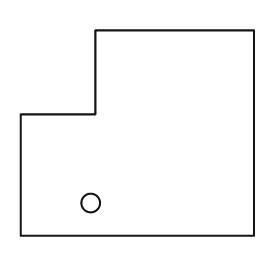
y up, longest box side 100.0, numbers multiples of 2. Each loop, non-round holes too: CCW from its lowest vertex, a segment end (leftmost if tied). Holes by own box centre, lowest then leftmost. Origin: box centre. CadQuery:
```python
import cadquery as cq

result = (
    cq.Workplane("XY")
    .moveTo(-50.0, -44.0)
    .lineTo(50.0, -44.0)
    .lineTo(50.0, 44.0)
    .lineTo(-18.0, 44.0)
    .lineTo(-18.0, 8.0)
    .lineTo(-50.0, 8.0)
    .close()
    .moveTo(-20.0, -30.0)
    .circle(4.0)
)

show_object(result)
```